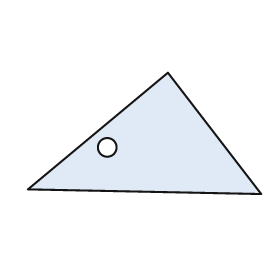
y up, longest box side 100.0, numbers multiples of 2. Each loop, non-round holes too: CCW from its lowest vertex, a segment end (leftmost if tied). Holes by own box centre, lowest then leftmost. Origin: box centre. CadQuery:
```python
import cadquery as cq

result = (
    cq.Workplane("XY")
    .moveTo(50.0, -26.0)
    .lineTo(10.0, 26.0)
    .lineTo(-50.0, -24.0)
    .close()
    .moveTo(-16.0, -6.0)
    .circle(4.0)
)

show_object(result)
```